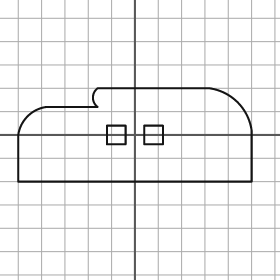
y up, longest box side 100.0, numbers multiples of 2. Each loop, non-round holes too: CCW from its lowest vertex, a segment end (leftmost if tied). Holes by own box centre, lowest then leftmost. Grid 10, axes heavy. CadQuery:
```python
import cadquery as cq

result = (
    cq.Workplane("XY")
    .moveTo(-50.0, -20.0)
    .lineTo(50.0, -20.0)
    .lineTo(50.0, 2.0)
    .threePointArc((44.0, 14.0), (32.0, 20.0))
    .lineTo(-16.0, 20.0)
    .threePointArc((-18.0, 16.0), (-16.0, 12.0))
    .lineTo(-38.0, 12.0)
    .threePointArc((-46.0, 8.0), (-50.0, 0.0))
    .close()
    .moveTo(-12.0, -4.0)
    .lineTo(-4.0, -4.0)
    .lineTo(-4.0, 4.0)
    .lineTo(-12.0, 4.0)
    .close()
    .moveTo(4.0, -4.0)
    .lineTo(12.0, -4.0)
    .lineTo(12.0, 4.0)
    .lineTo(4.0, 4.0)
    .close()
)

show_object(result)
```